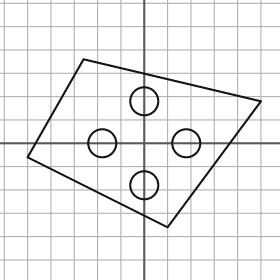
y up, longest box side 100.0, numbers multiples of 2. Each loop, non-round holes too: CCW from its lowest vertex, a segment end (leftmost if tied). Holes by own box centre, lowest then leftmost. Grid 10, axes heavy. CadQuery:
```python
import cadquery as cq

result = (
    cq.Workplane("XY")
    .moveTo(10.0, -36.0)
    .lineTo(50.0, 18.0)
    .lineTo(-26.0, 36.0)
    .lineTo(-50.0, -6.0)
    .close()
    .moveTo(0.0, -18.0)
    .circle(6.0)
    .moveTo(-18.0, 0.0)
    .circle(6.0)
    .moveTo(18.0, 0.0)
    .circle(6.0)
    .moveTo(0.0, 18.0)
    .circle(6.0)
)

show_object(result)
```